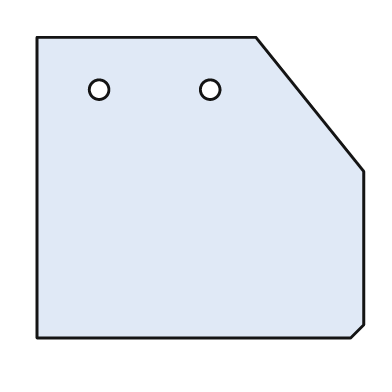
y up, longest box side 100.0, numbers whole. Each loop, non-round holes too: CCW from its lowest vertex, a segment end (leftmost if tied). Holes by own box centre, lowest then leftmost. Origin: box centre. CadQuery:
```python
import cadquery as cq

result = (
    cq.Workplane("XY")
    .moveTo(-50.0, -46.0)
    .lineTo(46.0, -46.0)
    .lineTo(50.0, -42.0)
    .lineTo(50.0, 5.0)
    .lineTo(17.0, 46.0)
    .lineTo(-50.0, 46.0)
    .close()
    .moveTo(-31.0, 30.0)
    .circle(3.0)
    .moveTo(3.0, 30.0)
    .circle(3.0)
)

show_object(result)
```